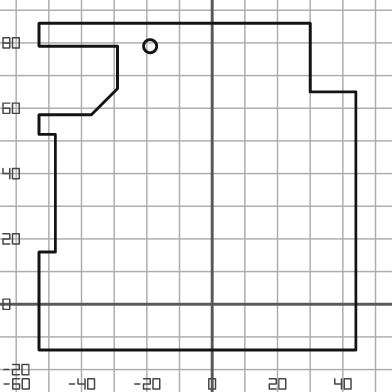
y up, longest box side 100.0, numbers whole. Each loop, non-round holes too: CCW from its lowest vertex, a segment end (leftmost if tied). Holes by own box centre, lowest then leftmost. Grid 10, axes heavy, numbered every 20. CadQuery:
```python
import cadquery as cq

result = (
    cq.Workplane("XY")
    .moveTo(-53.0, -14.0)
    .lineTo(44.0, -14.0)
    .lineTo(44.0, 65.0)
    .lineTo(30.0, 65.0)
    .lineTo(30.0, 86.0)
    .lineTo(-53.0, 86.0)
    .lineTo(-53.0, 79.0)
    .lineTo(-29.0, 79.0)
    .lineTo(-29.0, 66.0)
    .lineTo(-37.0, 58.0)
    .lineTo(-53.0, 58.0)
    .lineTo(-53.0, 52.0)
    .lineTo(-48.0, 52.0)
    .lineTo(-48.0, 16.0)
    .lineTo(-53.0, 16.0)
    .close()
    .moveTo(-19.0, 79.0)
    .circle(2.0)
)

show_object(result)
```